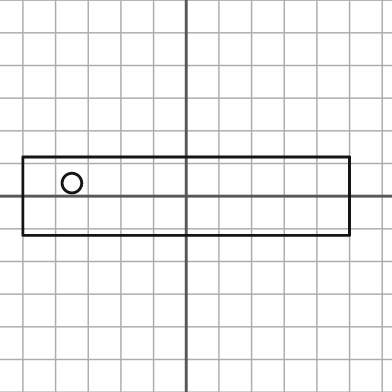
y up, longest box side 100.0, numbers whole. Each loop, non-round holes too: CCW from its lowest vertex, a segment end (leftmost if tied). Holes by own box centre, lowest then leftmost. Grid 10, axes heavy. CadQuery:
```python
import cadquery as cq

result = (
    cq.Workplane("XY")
    .moveTo(-50.0, -12.0)
    .lineTo(50.0, -12.0)
    .lineTo(50.0, 12.0)
    .lineTo(-50.0, 12.0)
    .close()
    .moveTo(-35.0, 4.0)
    .circle(3.0)
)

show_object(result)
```